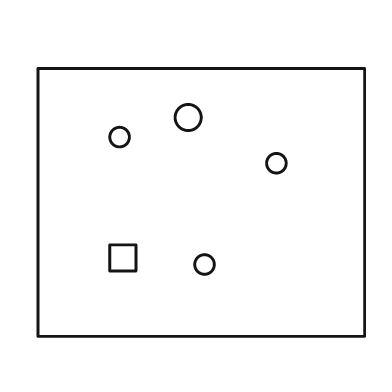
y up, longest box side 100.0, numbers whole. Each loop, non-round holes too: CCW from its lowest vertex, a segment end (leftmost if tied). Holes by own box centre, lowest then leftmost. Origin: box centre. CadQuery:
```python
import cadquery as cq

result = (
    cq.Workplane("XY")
    .moveTo(-50.0, -41.0)
    .lineTo(50.0, -41.0)
    .lineTo(50.0, 41.0)
    .lineTo(-50.0, 41.0)
    .close()
    .moveTo(1.0, -19.0)
    .circle(3.0)
    .moveTo(-28.0, -21.0)
    .lineTo(-20.0, -21.0)
    .lineTo(-20.0, -13.0)
    .lineTo(-28.0, -13.0)
    .close()
    .moveTo(23.0, 12.0)
    .circle(3.0)
    .moveTo(-25.0, 20.0)
    .circle(3.0)
    .moveTo(-4.0, 26.0)
    .circle(4.0)
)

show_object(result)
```